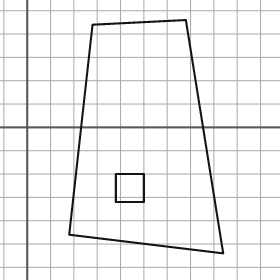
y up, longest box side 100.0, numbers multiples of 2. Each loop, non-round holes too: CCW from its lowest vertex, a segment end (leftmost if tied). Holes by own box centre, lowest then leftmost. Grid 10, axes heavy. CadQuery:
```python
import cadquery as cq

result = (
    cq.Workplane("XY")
    .moveTo(84.0, -54.0)
    .lineTo(68.0, 46.0)
    .lineTo(28.0, 44.0)
    .lineTo(18.0, -46.0)
    .close()
    .moveTo(38.0, -32.0)
    .lineTo(50.0, -32.0)
    .lineTo(50.0, -20.0)
    .lineTo(38.0, -20.0)
    .close()
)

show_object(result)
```